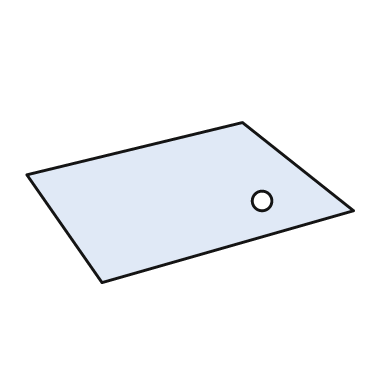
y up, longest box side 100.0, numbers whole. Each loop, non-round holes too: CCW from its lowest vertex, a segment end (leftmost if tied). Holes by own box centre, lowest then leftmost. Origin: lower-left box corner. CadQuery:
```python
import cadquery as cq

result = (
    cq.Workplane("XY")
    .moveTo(23.0, 0.0)
    .lineTo(100.0, 22.0)
    .lineTo(66.0, 49.0)
    .lineTo(0.0, 33.0)
    .close()
    .moveTo(72.0, 25.0)
    .circle(3.0)
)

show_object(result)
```